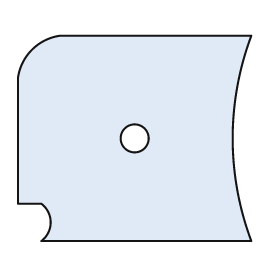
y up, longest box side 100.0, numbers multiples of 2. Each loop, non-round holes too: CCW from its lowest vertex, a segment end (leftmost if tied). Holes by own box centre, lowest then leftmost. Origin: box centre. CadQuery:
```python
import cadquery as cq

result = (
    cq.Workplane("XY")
    .moveTo(-40.0, -44.0)
    .lineTo(50.0, -44.0)
    .threePointArc((42.0, 0.0), (50.0, 44.0))
    .lineTo(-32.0, 44.0)
    .threePointArc((-44.0, 38.0), (-50.0, 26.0))
    .lineTo(-50.0, -28.0)
    .lineTo(-40.0, -28.0)
    .threePointArc((-36.0, -36.0), (-40.0, -44.0))
    .close()
    .moveTo(0.0, 0.0)
    .circle(6.0)
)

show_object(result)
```